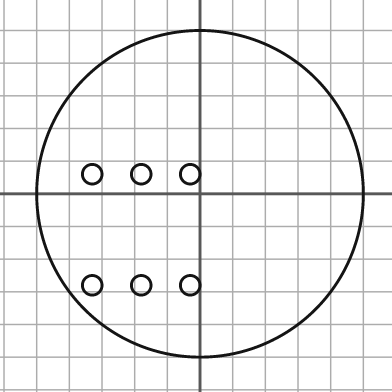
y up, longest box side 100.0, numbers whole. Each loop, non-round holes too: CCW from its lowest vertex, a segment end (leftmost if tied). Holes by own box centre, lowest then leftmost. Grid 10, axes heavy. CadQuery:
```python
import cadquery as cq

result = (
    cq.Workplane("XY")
    .moveTo(0.0, 0.0)
    .circle(50.0)
    .moveTo(-33.0, -28.0)
    .circle(3.0)
    .moveTo(-18.0, -28.0)
    .circle(3.0)
    .moveTo(-3.0, -28.0)
    .circle(3.0)
    .moveTo(-33.0, 6.0)
    .circle(3.0)
    .moveTo(-18.0, 6.0)
    .circle(3.0)
    .moveTo(-3.0, 6.0)
    .circle(3.0)
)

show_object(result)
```